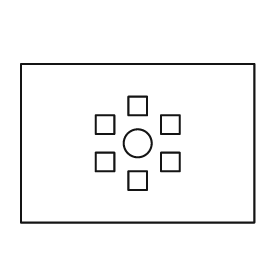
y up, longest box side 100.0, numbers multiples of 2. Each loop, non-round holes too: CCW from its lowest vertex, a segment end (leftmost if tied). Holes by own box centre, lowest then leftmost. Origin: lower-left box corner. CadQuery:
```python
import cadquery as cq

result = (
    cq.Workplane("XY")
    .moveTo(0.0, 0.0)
    .lineTo(100.0, 0.0)
    .lineTo(100.0, 68.0)
    .lineTo(0.0, 68.0)
    .close()
    .moveTo(46.0, 14.0)
    .lineTo(54.0, 14.0)
    .lineTo(54.0, 22.0)
    .lineTo(46.0, 22.0)
    .close()
    .moveTo(32.0, 22.0)
    .lineTo(40.0, 22.0)
    .lineTo(40.0, 30.0)
    .lineTo(32.0, 30.0)
    .close()
    .moveTo(60.0, 22.0)
    .lineTo(68.0, 22.0)
    .lineTo(68.0, 30.0)
    .lineTo(60.0, 30.0)
    .close()
    .moveTo(50.0, 34.0)
    .circle(6.0)
    .moveTo(32.0, 38.0)
    .lineTo(40.0, 38.0)
    .lineTo(40.0, 46.0)
    .lineTo(32.0, 46.0)
    .close()
    .moveTo(60.0, 38.0)
    .lineTo(68.0, 38.0)
    .lineTo(68.0, 46.0)
    .lineTo(60.0, 46.0)
    .close()
    .moveTo(46.0, 46.0)
    .lineTo(54.0, 46.0)
    .lineTo(54.0, 54.0)
    .lineTo(46.0, 54.0)
    .close()
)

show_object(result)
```